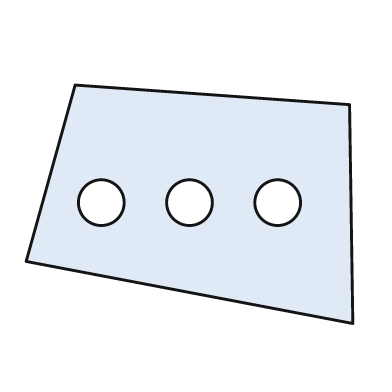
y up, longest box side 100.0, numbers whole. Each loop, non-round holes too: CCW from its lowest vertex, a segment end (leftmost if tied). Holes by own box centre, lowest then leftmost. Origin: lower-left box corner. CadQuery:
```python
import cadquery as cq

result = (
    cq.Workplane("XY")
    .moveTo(100.0, 0.0)
    .lineTo(99.0, 67.0)
    .lineTo(15.0, 73.0)
    .lineTo(0.0, 19.0)
    .close()
    .moveTo(23.0, 37.0)
    .circle(7.0)
    .moveTo(50.0, 37.0)
    .circle(7.0)
    .moveTo(77.0, 37.0)
    .circle(7.0)
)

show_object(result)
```